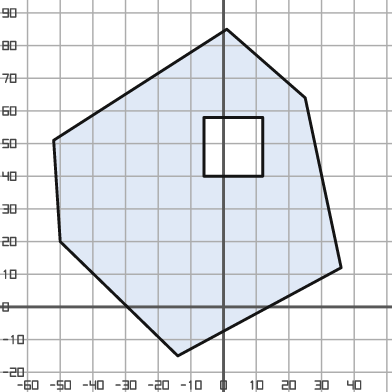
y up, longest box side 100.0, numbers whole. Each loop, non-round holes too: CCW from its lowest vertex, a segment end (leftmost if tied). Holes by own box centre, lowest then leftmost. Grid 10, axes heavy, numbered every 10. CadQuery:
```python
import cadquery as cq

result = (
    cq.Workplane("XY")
    .moveTo(-14.0, -15.0)
    .lineTo(36.0, 12.0)
    .lineTo(25.0, 64.0)
    .lineTo(1.0, 85.0)
    .lineTo(-52.0, 51.0)
    .lineTo(-50.0, 20.0)
    .close()
    .moveTo(-6.0, 40.0)
    .lineTo(12.0, 40.0)
    .lineTo(12.0, 58.0)
    .lineTo(-6.0, 58.0)
    .close()
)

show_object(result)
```